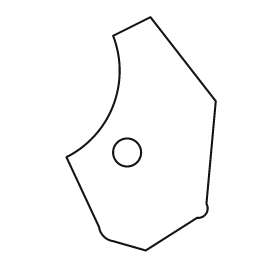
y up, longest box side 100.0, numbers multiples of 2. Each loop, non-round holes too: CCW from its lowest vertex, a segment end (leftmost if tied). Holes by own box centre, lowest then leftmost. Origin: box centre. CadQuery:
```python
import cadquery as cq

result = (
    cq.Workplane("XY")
    .moveTo(2.0, -50.0)
    .lineTo(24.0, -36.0)
    .threePointArc((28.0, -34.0), (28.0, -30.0))
    .lineTo(32.0, 14.0)
    .lineTo(4.0, 50.0)
    .lineTo(-12.0, 42.0)
    .threePointArc((-12.0, 12.0), (-32.0, -10.0))
    .lineTo(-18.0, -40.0)
    .threePointArc((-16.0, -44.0), (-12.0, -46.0))
    .close()
    .moveTo(-6.0, -8.0)
    .circle(6.0)
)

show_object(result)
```